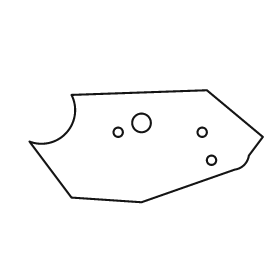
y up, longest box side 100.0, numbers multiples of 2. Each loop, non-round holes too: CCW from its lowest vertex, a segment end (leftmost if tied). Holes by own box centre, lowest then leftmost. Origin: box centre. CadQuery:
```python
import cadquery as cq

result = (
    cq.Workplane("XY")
    .moveTo(-2.0, -24.0)
    .lineTo(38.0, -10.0)
    .threePointArc((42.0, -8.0), (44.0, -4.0))
    .lineTo(50.0, 4.0)
    .lineTo(26.0, 24.0)
    .lineTo(-32.0, 22.0)
    .threePointArc((-34.0, 6.0), (-50.0, 2.0))
    .lineTo(-32.0, -22.0)
    .close()
    .moveTo(28.0, -6.0)
    .circle(2.0)
    .moveTo(-12.0, 6.0)
    .circle(2.0)
    .moveTo(24.0, 6.0)
    .circle(2.0)
    .moveTo(-2.0, 10.0)
    .circle(4.0)
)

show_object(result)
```